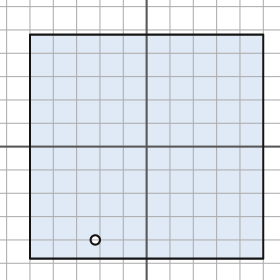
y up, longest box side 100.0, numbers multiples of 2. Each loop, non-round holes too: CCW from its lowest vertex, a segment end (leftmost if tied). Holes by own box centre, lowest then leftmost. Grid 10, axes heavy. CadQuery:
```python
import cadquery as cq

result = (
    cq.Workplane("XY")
    .moveTo(-50.0, -48.0)
    .lineTo(50.0, -48.0)
    .lineTo(50.0, 48.0)
    .lineTo(-50.0, 48.0)
    .close()
    .moveTo(-22.0, -40.0)
    .circle(2.0)
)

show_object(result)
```